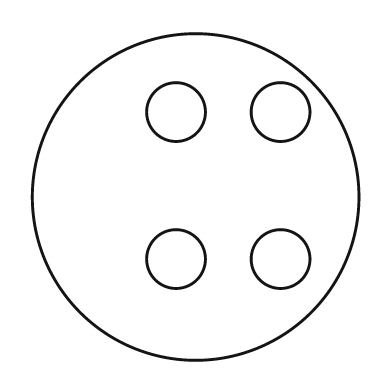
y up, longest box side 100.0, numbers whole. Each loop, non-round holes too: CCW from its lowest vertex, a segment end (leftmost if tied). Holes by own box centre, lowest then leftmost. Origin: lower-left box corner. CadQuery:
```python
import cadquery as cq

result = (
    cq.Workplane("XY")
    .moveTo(50.0, 50.0)
    .circle(50.0)
    .moveTo(44.0, 31.0)
    .circle(9.0)
    .moveTo(76.0, 31.0)
    .circle(9.0)
    .moveTo(44.0, 76.0)
    .circle(9.0)
    .moveTo(76.0, 76.0)
    .circle(9.0)
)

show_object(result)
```